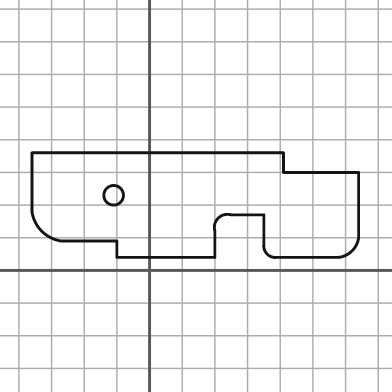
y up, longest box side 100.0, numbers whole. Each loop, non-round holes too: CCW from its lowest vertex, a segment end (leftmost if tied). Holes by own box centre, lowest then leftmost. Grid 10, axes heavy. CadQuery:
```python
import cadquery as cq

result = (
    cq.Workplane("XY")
    .moveTo(-10.0, 4.0)
    .lineTo(20.0, 4.0)
    .lineTo(20.0, 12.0)
    .threePointArc((21.0, 16.0), (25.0, 17.0))
    .lineTo(35.0, 17.0)
    .lineTo(35.0, 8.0)
    .threePointArc((36.0, 5.0), (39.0, 4.0))
    .lineTo(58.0, 4.0)
    .threePointArc((62.0, 6.0), (64.0, 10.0))
    .lineTo(64.0, 30.0)
    .lineTo(41.0, 30.0)
    .lineTo(41.0, 36.0)
    .lineTo(-36.0, 36.0)
    .lineTo(-36.0, 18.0)
    .threePointArc((-33.0, 12.0), (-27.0, 9.0))
    .lineTo(-10.0, 9.0)
    .close()
    .moveTo(-11.0, 23.0)
    .circle(3.0)
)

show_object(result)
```